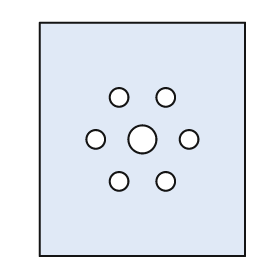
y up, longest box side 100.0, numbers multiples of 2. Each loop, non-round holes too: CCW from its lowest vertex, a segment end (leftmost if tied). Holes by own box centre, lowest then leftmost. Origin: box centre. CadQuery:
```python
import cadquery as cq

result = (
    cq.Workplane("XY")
    .moveTo(-44.0, -50.0)
    .lineTo(44.0, -50.0)
    .lineTo(44.0, 50.0)
    .lineTo(-44.0, 50.0)
    .close()
    .moveTo(-10.0, -18.0)
    .circle(4.0)
    .moveTo(10.0, -18.0)
    .circle(4.0)
    .moveTo(-20.0, 0.0)
    .circle(4.0)
    .moveTo(0.0, 0.0)
    .circle(6.0)
    .moveTo(20.0, 0.0)
    .circle(4.0)
    .moveTo(-10.0, 18.0)
    .circle(4.0)
    .moveTo(10.0, 18.0)
    .circle(4.0)
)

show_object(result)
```